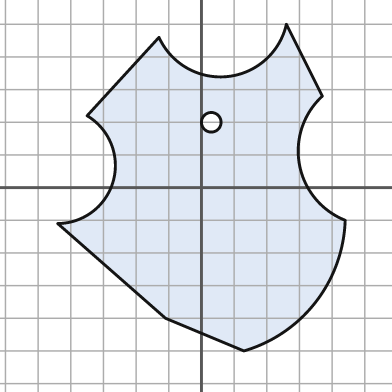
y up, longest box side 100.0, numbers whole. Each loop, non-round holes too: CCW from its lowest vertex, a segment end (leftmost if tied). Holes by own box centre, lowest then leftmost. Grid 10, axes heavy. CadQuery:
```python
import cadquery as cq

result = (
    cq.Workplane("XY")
    .moveTo(13.0, -50.0)
    .threePointArc((35.0, -35.0), (44.0, -10.0))
    .threePointArc((30.0, 7.0), (37.0, 28.0))
    .lineTo(26.0, 50.0)
    .threePointArc((8.0, 34.0), (-13.0, 46.0))
    .lineTo(-35.0, 22.0)
    .threePointArc((-27.0, 2.0), (-44.0, -11.0))
    .lineTo(-11.0, -40.0)
    .close()
    .moveTo(3.0, 20.0)
    .circle(3.0)
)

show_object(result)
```